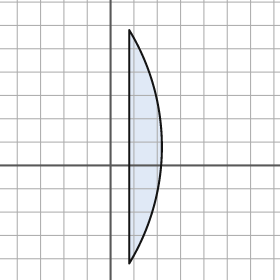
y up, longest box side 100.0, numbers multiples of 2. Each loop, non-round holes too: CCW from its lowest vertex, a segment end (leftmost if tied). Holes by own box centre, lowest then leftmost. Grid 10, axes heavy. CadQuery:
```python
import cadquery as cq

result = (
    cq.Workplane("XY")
    .moveTo(8.0, -42.0)
    .threePointArc((22.0, 8.0), (8.0, 58.0))
    .close()
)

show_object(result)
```